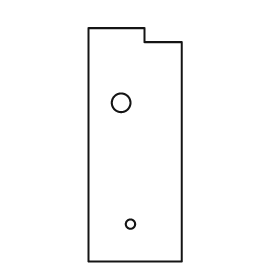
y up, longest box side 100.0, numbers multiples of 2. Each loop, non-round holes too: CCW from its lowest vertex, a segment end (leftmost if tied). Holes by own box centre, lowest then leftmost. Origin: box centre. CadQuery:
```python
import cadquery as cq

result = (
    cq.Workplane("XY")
    .moveTo(-20.0, -50.0)
    .lineTo(20.0, -50.0)
    .lineTo(20.0, 44.0)
    .lineTo(4.0, 44.0)
    .lineTo(4.0, 50.0)
    .lineTo(-20.0, 50.0)
    .close()
    .moveTo(-2.0, -34.0)
    .circle(2.0)
    .moveTo(-6.0, 18.0)
    .circle(4.0)
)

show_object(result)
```